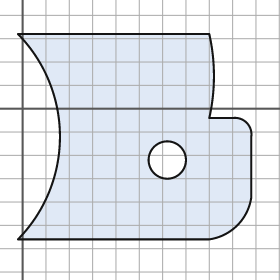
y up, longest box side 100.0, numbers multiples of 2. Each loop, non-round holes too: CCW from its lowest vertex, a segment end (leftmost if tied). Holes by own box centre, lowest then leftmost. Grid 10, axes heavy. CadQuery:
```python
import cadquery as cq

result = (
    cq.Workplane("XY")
    .moveTo(-2.0, -56.0)
    .lineTo(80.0, -56.0)
    .threePointArc((92.0, -50.0), (98.0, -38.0))
    .lineTo(98.0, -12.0)
    .threePointArc((96.0, -6.0), (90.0, -4.0))
    .lineTo(80.0, -4.0)
    .threePointArc((82.0, 14.0), (80.0, 32.0))
    .lineTo(-2.0, 32.0)
    .threePointArc((16.0, -12.0), (-2.0, -56.0))
    .close()
    .moveTo(62.0, -22.0)
    .circle(8.0)
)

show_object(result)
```